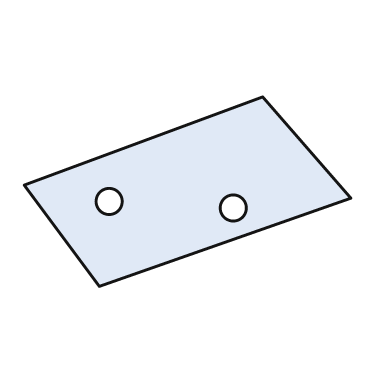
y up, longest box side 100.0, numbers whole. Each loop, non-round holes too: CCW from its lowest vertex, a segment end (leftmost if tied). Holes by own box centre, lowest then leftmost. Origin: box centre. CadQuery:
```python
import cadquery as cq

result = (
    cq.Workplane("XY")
    .moveTo(-27.0, -29.0)
    .lineTo(50.0, -2.0)
    .lineTo(23.0, 29.0)
    .lineTo(-50.0, 2.0)
    .close()
    .moveTo(14.0, -5.0)
    .circle(4.0)
    .moveTo(-24.0, -3.0)
    .circle(4.0)
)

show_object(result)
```